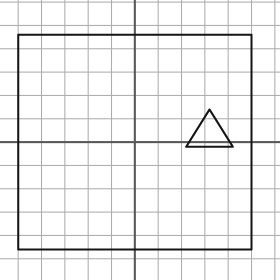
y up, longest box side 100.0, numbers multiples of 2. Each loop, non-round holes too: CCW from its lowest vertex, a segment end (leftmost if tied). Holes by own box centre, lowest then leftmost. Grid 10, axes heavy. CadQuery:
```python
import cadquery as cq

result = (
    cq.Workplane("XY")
    .moveTo(-50.0, -46.0)
    .lineTo(50.0, -46.0)
    .lineTo(50.0, 46.0)
    .lineTo(-50.0, 46.0)
    .close()
    .moveTo(22.0, -2.0)
    .lineTo(42.0, -2.0)
    .lineTo(32.0, 14.0)
    .close()
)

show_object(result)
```